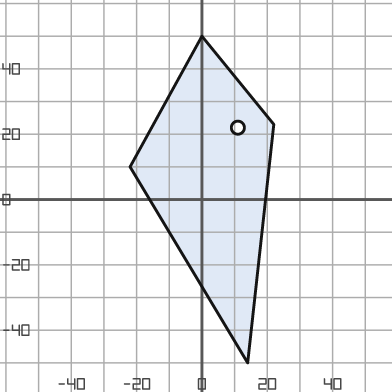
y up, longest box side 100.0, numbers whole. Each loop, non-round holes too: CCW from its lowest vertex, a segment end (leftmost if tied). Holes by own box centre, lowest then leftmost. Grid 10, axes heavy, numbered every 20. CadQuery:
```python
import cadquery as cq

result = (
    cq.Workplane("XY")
    .moveTo(14.0, -50.0)
    .lineTo(22.0, 23.0)
    .lineTo(0.0, 50.0)
    .lineTo(-22.0, 10.0)
    .close()
    .moveTo(11.0, 22.0)
    .circle(2.0)
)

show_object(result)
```